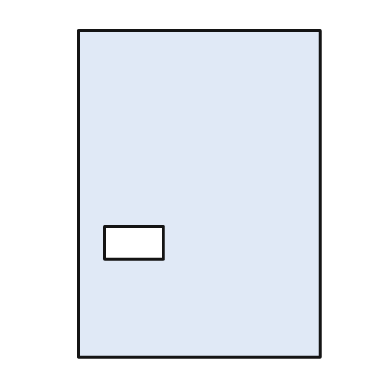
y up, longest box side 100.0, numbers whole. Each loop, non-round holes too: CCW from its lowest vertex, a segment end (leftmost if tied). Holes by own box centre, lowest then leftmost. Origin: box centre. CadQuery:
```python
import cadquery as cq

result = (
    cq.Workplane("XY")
    .moveTo(-37.0, -50.0)
    .lineTo(37.0, -50.0)
    .lineTo(37.0, 50.0)
    .lineTo(-37.0, 50.0)
    .close()
    .moveTo(-29.0, -20.0)
    .lineTo(-11.0, -20.0)
    .lineTo(-11.0, -10.0)
    .lineTo(-29.0, -10.0)
    .close()
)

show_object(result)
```